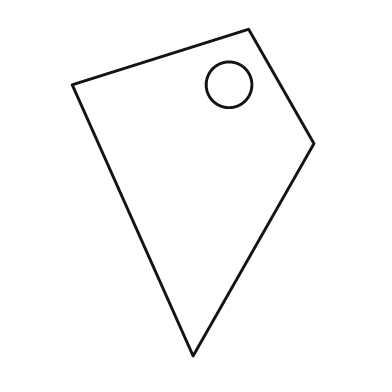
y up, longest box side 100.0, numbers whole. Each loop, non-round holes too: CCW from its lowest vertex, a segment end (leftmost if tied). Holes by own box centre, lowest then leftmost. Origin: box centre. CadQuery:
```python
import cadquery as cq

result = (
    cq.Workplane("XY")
    .moveTo(0.0, -50.0)
    .lineTo(37.0, 15.0)
    .lineTo(17.0, 50.0)
    .lineTo(-37.0, 33.0)
    .close()
    .moveTo(11.0, 33.0)
    .circle(7.0)
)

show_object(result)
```